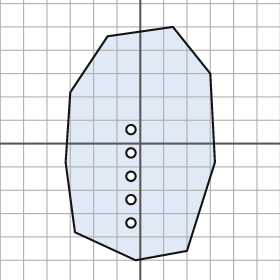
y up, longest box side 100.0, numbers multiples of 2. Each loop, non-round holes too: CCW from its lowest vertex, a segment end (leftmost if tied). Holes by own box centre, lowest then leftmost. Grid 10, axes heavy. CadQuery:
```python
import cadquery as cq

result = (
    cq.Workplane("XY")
    .moveTo(-2.0, -50.0)
    .lineTo(20.0, -46.0)
    .lineTo(32.0, -8.0)
    .lineTo(30.0, 30.0)
    .lineTo(14.0, 50.0)
    .lineTo(-14.0, 46.0)
    .lineTo(-30.0, 22.0)
    .lineTo(-32.0, -8.0)
    .lineTo(-28.0, -38.0)
    .close()
    .moveTo(-4.0, -34.0)
    .circle(2.0)
    .moveTo(-4.0, -24.0)
    .circle(2.0)
    .moveTo(-4.0, -14.0)
    .circle(2.0)
    .moveTo(-4.0, -4.0)
    .circle(2.0)
    .moveTo(-4.0, 6.0)
    .circle(2.0)
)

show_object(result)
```